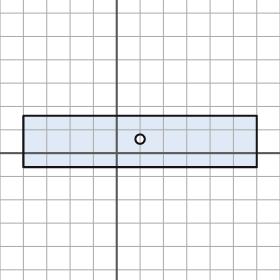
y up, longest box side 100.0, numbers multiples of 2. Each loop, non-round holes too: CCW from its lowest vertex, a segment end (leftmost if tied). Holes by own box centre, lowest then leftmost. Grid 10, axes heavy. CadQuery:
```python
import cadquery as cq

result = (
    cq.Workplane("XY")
    .moveTo(-40.0, -6.0)
    .lineTo(60.0, -6.0)
    .lineTo(60.0, 16.0)
    .lineTo(-40.0, 16.0)
    .close()
    .moveTo(10.0, 6.0)
    .circle(2.0)
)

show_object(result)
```